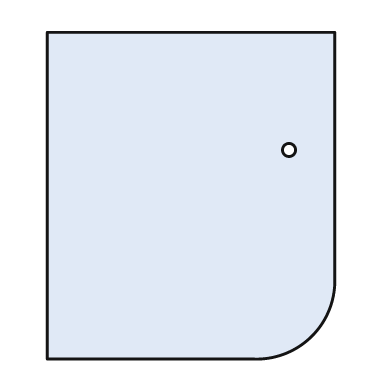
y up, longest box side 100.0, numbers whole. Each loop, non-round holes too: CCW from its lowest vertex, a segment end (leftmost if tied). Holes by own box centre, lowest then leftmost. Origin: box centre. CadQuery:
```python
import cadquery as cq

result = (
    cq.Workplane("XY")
    .moveTo(-44.0, -50.0)
    .lineTo(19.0, -50.0)
    .threePointArc((37.0, -43.0), (44.0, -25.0))
    .lineTo(44.0, 50.0)
    .lineTo(-44.0, 50.0)
    .close()
    .moveTo(30.0, 14.0)
    .circle(2.0)
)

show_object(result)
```